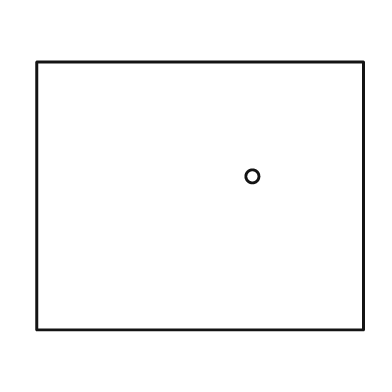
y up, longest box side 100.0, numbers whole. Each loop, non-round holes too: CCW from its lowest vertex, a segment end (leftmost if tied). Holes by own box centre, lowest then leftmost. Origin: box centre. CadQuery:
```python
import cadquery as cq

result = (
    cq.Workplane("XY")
    .moveTo(-50.0, -41.0)
    .lineTo(50.0, -41.0)
    .lineTo(50.0, 41.0)
    .lineTo(-50.0, 41.0)
    .close()
    .moveTo(16.0, 6.0)
    .circle(2.0)
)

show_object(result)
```